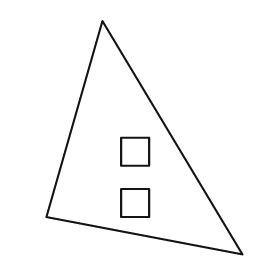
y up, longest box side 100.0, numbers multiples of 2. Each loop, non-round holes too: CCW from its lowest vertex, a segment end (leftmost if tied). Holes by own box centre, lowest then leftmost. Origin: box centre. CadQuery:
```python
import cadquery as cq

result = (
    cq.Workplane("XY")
    .moveTo(42.0, -50.0)
    .lineTo(-18.0, 50.0)
    .lineTo(-42.0, -34.0)
    .close()
    .moveTo(-10.0, -34.0)
    .lineTo(2.0, -34.0)
    .lineTo(2.0, -22.0)
    .lineTo(-10.0, -22.0)
    .close()
    .moveTo(-10.0, -12.0)
    .lineTo(2.0, -12.0)
    .lineTo(2.0, 0.0)
    .lineTo(-10.0, 0.0)
    .close()
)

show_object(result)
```